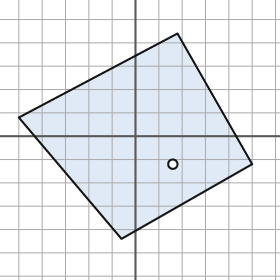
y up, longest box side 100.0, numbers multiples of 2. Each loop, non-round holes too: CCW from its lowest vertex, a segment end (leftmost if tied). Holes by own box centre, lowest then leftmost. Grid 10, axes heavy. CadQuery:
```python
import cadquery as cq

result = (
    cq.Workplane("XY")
    .moveTo(-6.0, -44.0)
    .lineTo(50.0, -12.0)
    .lineTo(18.0, 44.0)
    .lineTo(-50.0, 8.0)
    .close()
    .moveTo(16.0, -12.0)
    .circle(2.0)
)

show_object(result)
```